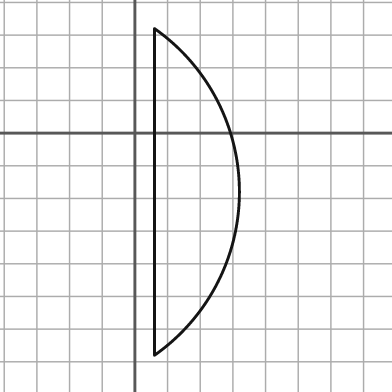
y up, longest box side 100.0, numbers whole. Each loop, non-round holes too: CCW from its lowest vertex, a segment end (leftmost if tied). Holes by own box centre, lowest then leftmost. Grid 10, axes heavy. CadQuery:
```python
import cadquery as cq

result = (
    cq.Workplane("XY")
    .moveTo(6.0, -68.0)
    .threePointArc((32.0, -18.0), (6.0, 32.0))
    .close()
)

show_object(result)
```